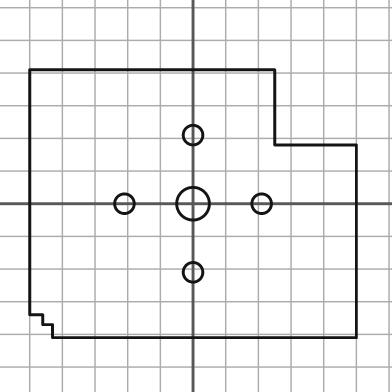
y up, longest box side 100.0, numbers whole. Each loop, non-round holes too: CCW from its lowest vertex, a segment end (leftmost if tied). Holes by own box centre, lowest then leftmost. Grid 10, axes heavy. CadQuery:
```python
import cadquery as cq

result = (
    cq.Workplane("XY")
    .moveTo(-43.0, -41.0)
    .lineTo(50.0, -41.0)
    .lineTo(50.0, 18.0)
    .lineTo(25.0, 18.0)
    .lineTo(25.0, 41.0)
    .lineTo(-50.0, 41.0)
    .lineTo(-50.0, -34.0)
    .lineTo(-46.0, -34.0)
    .lineTo(-46.0, -37.0)
    .lineTo(-43.0, -37.0)
    .close()
    .moveTo(0.0, -21.0)
    .circle(3.0)
    .moveTo(-21.0, 0.0)
    .circle(3.0)
    .moveTo(0.0, 0.0)
    .circle(5.0)
    .moveTo(21.0, 0.0)
    .circle(3.0)
    .moveTo(0.0, 21.0)
    .circle(3.0)
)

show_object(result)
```